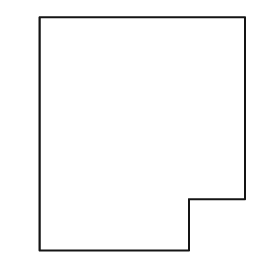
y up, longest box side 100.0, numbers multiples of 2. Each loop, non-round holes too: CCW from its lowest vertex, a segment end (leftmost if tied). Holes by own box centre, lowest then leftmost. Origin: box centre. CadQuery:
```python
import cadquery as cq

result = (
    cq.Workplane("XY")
    .moveTo(-44.0, -50.0)
    .lineTo(20.0, -50.0)
    .lineTo(20.0, -28.0)
    .lineTo(44.0, -28.0)
    .lineTo(44.0, 50.0)
    .lineTo(-44.0, 50.0)
    .close()
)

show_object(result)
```